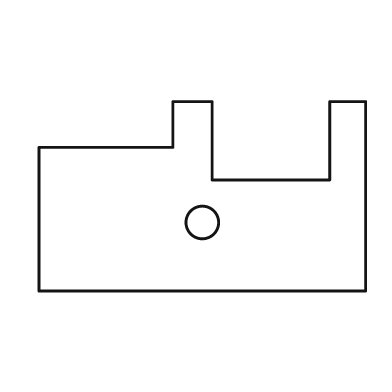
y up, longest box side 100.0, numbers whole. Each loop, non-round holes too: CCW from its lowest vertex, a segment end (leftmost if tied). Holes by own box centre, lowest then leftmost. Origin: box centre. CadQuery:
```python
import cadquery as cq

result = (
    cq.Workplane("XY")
    .moveTo(-50.0, -29.0)
    .lineTo(50.0, -29.0)
    .lineTo(50.0, 29.0)
    .lineTo(39.0, 29.0)
    .lineTo(39.0, 5.0)
    .lineTo(3.0, 5.0)
    .lineTo(3.0, 29.0)
    .lineTo(-9.0, 29.0)
    .lineTo(-9.0, 15.0)
    .lineTo(-50.0, 15.0)
    .close()
    .moveTo(0.0, -8.0)
    .circle(5.0)
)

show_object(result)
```